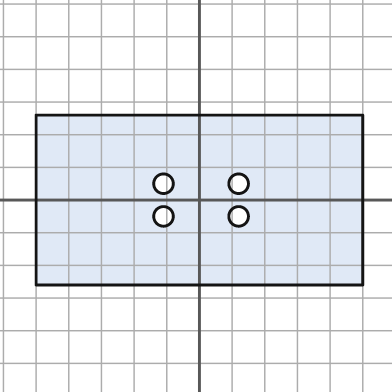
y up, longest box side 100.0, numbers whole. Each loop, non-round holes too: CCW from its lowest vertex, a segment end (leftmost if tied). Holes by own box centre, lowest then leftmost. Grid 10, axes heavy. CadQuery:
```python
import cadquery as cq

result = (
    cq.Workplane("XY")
    .moveTo(-50.0, -26.0)
    .lineTo(50.0, -26.0)
    .lineTo(50.0, 26.0)
    .lineTo(-50.0, 26.0)
    .close()
    .moveTo(-11.0, -5.0)
    .circle(3.0)
    .moveTo(12.0, -5.0)
    .circle(3.0)
    .moveTo(-11.0, 5.0)
    .circle(3.0)
    .moveTo(12.0, 5.0)
    .circle(3.0)
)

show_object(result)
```